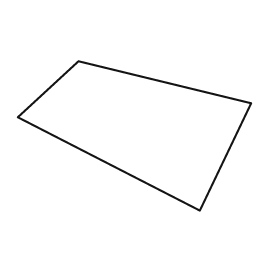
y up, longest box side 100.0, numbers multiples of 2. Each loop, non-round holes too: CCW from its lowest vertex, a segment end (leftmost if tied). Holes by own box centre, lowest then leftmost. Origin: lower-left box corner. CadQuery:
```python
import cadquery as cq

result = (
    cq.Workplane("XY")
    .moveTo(78.0, 0.0)
    .lineTo(100.0, 46.0)
    .lineTo(26.0, 64.0)
    .lineTo(0.0, 40.0)
    .close()
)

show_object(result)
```